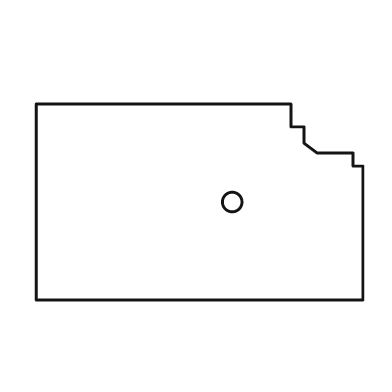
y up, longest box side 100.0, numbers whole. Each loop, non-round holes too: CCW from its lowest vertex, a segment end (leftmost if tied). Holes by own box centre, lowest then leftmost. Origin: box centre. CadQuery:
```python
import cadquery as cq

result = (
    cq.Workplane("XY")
    .moveTo(-50.0, -30.0)
    .lineTo(50.0, -30.0)
    .lineTo(50.0, 11.0)
    .lineTo(47.0, 11.0)
    .lineTo(47.0, 15.0)
    .lineTo(36.0, 15.0)
    .lineTo(32.0, 18.0)
    .lineTo(32.0, 23.0)
    .lineTo(28.0, 23.0)
    .lineTo(28.0, 30.0)
    .lineTo(-50.0, 30.0)
    .close()
    .moveTo(10.0, 0.0)
    .circle(3.0)
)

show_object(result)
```